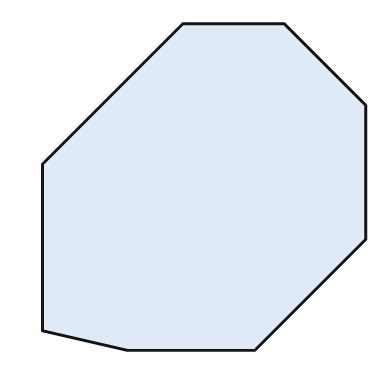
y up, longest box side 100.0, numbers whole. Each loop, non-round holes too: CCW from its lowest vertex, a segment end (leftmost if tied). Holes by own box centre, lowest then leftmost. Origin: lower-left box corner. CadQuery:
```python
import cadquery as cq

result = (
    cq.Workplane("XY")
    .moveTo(26.0, 0.0)
    .lineTo(65.0, 0.0)
    .lineTo(99.0, 34.0)
    .lineTo(99.0, 75.0)
    .lineTo(74.0, 100.0)
    .lineTo(43.0, 100.0)
    .lineTo(0.0, 57.0)
    .lineTo(0.0, 6.0)
    .close()
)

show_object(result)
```